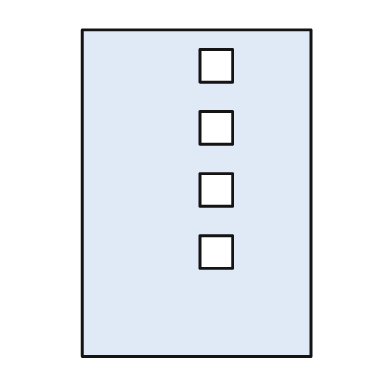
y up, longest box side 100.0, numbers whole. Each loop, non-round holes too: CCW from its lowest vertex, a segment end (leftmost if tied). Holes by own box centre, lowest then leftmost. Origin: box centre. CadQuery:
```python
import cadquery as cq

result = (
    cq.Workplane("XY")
    .moveTo(-35.0, -50.0)
    .lineTo(35.0, -50.0)
    .lineTo(35.0, 50.0)
    .lineTo(-35.0, 50.0)
    .close()
    .moveTo(1.0, -23.0)
    .lineTo(11.0, -23.0)
    .lineTo(11.0, -13.0)
    .lineTo(1.0, -13.0)
    .close()
    .moveTo(1.0, -4.0)
    .lineTo(11.0, -4.0)
    .lineTo(11.0, 6.0)
    .lineTo(1.0, 6.0)
    .close()
    .moveTo(1.0, 15.0)
    .lineTo(11.0, 15.0)
    .lineTo(11.0, 25.0)
    .lineTo(1.0, 25.0)
    .close()
    .moveTo(1.0, 34.0)
    .lineTo(11.0, 34.0)
    .lineTo(11.0, 44.0)
    .lineTo(1.0, 44.0)
    .close()
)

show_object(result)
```